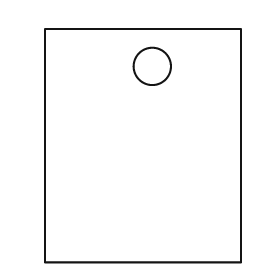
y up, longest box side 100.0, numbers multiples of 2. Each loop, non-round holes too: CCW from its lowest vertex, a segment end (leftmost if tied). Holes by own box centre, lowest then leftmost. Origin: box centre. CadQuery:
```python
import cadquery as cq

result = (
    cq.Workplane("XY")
    .moveTo(-42.0, -50.0)
    .lineTo(42.0, -50.0)
    .lineTo(42.0, 50.0)
    .lineTo(-42.0, 50.0)
    .close()
    .moveTo(4.0, 34.0)
    .circle(8.0)
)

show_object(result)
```